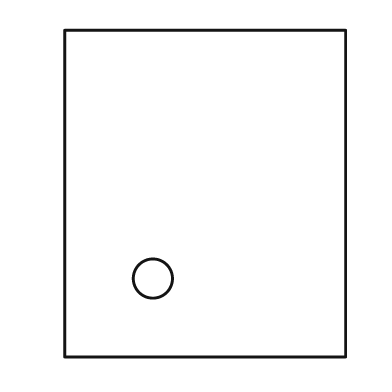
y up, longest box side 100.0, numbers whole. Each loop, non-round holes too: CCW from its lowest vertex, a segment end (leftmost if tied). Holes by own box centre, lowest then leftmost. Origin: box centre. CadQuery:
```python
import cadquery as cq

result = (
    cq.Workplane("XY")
    .moveTo(-43.0, -50.0)
    .lineTo(43.0, -50.0)
    .lineTo(43.0, 50.0)
    .lineTo(-43.0, 50.0)
    .close()
    .moveTo(-16.0, -26.0)
    .circle(6.0)
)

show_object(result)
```